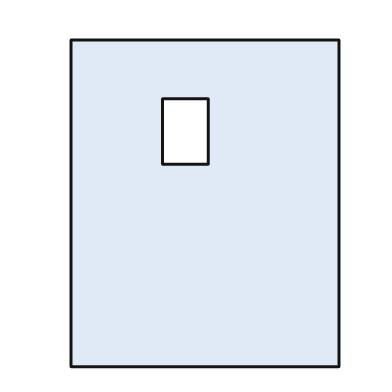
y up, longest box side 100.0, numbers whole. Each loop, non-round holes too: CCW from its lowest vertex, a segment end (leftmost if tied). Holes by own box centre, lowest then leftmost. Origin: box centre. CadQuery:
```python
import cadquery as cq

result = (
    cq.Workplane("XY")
    .moveTo(-41.0, -50.0)
    .lineTo(41.0, -50.0)
    .lineTo(41.0, 50.0)
    .lineTo(-41.0, 50.0)
    .close()
    .moveTo(-13.0, 12.0)
    .lineTo(1.0, 12.0)
    .lineTo(1.0, 32.0)
    .lineTo(-13.0, 32.0)
    .close()
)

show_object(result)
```